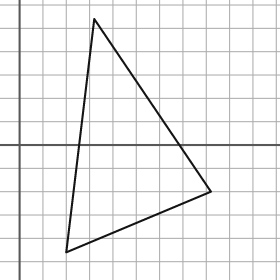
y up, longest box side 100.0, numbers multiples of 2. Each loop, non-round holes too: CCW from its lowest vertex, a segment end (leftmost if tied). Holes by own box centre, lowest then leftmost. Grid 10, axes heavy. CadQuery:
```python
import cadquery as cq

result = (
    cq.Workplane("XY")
    .moveTo(20.0, -46.0)
    .lineTo(82.0, -20.0)
    .lineTo(32.0, 54.0)
    .close()
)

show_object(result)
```